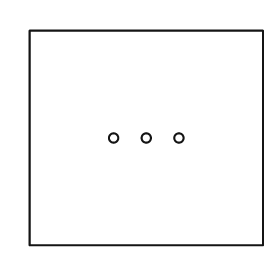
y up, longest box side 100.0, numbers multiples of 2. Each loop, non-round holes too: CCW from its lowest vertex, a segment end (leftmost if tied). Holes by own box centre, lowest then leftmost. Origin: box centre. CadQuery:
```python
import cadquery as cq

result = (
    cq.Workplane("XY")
    .moveTo(-50.0, -46.0)
    .lineTo(50.0, -46.0)
    .lineTo(50.0, 46.0)
    .lineTo(-50.0, 46.0)
    .close()
    .moveTo(-14.0, 0.0)
    .circle(2.0)
    .moveTo(0.0, 0.0)
    .circle(2.0)
    .moveTo(14.0, 0.0)
    .circle(2.0)
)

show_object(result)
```